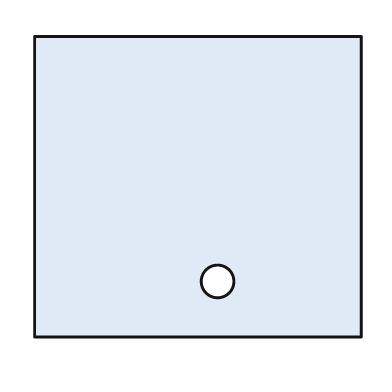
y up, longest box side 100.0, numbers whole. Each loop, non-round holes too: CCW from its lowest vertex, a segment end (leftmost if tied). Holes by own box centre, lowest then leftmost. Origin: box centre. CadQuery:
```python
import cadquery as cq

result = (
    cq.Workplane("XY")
    .moveTo(-50.0, -46.0)
    .lineTo(50.0, -46.0)
    .lineTo(50.0, 46.0)
    .lineTo(-50.0, 46.0)
    .close()
    .moveTo(6.0, -29.0)
    .circle(5.0)
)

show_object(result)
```